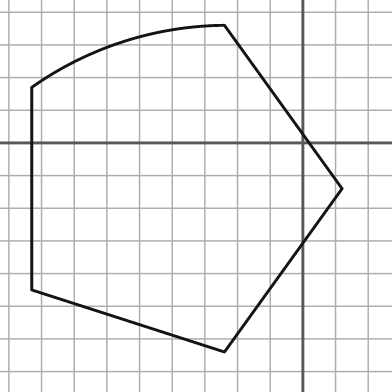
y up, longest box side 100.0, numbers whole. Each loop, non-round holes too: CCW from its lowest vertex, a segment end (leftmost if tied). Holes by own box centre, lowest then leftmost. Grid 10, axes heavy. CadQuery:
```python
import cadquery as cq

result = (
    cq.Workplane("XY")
    .moveTo(-24.0, -64.0)
    .lineTo(12.0, -14.0)
    .lineTo(-24.0, 36.0)
    .threePointArc((-55.0, 31.0), (-83.0, 17.0))
    .lineTo(-83.0, -45.0)
    .close()
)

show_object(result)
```